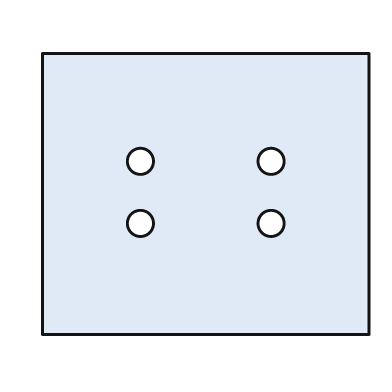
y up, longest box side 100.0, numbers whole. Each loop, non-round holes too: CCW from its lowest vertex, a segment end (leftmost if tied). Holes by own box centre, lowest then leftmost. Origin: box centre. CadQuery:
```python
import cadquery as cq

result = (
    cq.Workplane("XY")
    .moveTo(-50.0, -43.0)
    .lineTo(50.0, -43.0)
    .lineTo(50.0, 43.0)
    .lineTo(-50.0, 43.0)
    .close()
    .moveTo(-20.0, -9.0)
    .circle(4.0)
    .moveTo(20.0, -9.0)
    .circle(4.0)
    .moveTo(-20.0, 10.0)
    .circle(4.0)
    .moveTo(20.0, 10.0)
    .circle(4.0)
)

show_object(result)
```